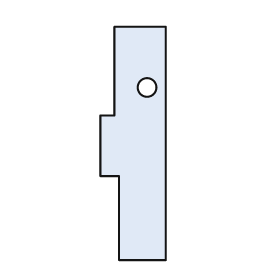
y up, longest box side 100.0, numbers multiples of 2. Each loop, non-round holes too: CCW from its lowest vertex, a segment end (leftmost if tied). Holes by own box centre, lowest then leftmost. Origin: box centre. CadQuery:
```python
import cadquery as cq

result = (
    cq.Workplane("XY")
    .moveTo(-6.0, -50.0)
    .lineTo(14.0, -50.0)
    .lineTo(14.0, 50.0)
    .lineTo(-8.0, 50.0)
    .lineTo(-8.0, 12.0)
    .lineTo(-14.0, 12.0)
    .lineTo(-14.0, -14.0)
    .lineTo(-6.0, -14.0)
    .close()
    .moveTo(6.0, 24.0)
    .circle(4.0)
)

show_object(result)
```